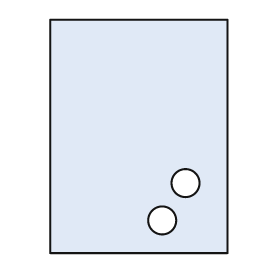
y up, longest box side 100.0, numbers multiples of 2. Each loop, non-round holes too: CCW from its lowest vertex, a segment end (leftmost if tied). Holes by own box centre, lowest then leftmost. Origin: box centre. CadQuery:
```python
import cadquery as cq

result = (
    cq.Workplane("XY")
    .moveTo(-38.0, -50.0)
    .lineTo(38.0, -50.0)
    .lineTo(38.0, 50.0)
    .lineTo(-38.0, 50.0)
    .close()
    .moveTo(10.0, -36.0)
    .circle(6.0)
    .moveTo(20.0, -20.0)
    .circle(6.0)
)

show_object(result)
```